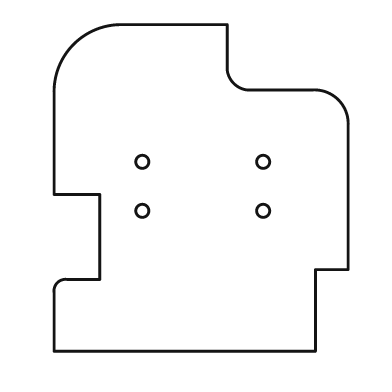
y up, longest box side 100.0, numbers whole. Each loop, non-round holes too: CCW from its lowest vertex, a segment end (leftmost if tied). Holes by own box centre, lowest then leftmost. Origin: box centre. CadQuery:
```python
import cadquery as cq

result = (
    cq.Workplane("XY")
    .moveTo(-45.0, -50.0)
    .lineTo(35.0, -50.0)
    .lineTo(35.0, -25.0)
    .lineTo(45.0, -25.0)
    .lineTo(45.0, 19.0)
    .threePointArc((42.0, 27.0), (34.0, 30.0))
    .lineTo(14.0, 30.0)
    .threePointArc((10.0, 32.0), (8.0, 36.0))
    .lineTo(8.0, 50.0)
    .lineTo(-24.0, 50.0)
    .threePointArc((-39.0, 44.0), (-45.0, 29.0))
    .lineTo(-45.0, -2.0)
    .lineTo(-31.0, -2.0)
    .lineTo(-31.0, -28.0)
    .lineTo(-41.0, -28.0)
    .threePointArc((-44.0, -29.0), (-45.0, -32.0))
    .close()
    .moveTo(-18.0, -7.0)
    .circle(2.0)
    .moveTo(19.0, -7.0)
    .circle(2.0)
    .moveTo(-18.0, 8.0)
    .circle(2.0)
    .moveTo(19.0, 8.0)
    .circle(2.0)
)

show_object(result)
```